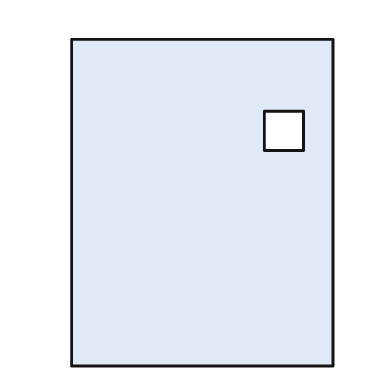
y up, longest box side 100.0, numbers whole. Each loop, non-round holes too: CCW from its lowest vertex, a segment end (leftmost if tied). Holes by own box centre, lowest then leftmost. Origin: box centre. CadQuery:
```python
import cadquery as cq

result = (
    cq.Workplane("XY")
    .moveTo(-40.0, -50.0)
    .lineTo(40.0, -50.0)
    .lineTo(40.0, 50.0)
    .lineTo(-40.0, 50.0)
    .close()
    .moveTo(19.0, 16.0)
    .lineTo(31.0, 16.0)
    .lineTo(31.0, 28.0)
    .lineTo(19.0, 28.0)
    .close()
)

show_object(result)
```